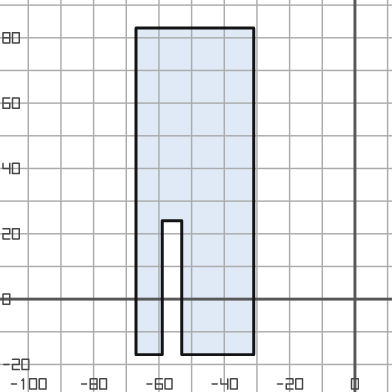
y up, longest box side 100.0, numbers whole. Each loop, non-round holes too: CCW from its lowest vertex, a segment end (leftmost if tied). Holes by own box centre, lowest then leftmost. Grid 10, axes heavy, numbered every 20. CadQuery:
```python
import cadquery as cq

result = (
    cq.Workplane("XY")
    .moveTo(-67.0, -17.0)
    .lineTo(-59.0, -17.0)
    .lineTo(-59.0, 24.0)
    .lineTo(-53.0, 24.0)
    .lineTo(-53.0, -17.0)
    .lineTo(-31.0, -17.0)
    .lineTo(-31.0, 83.0)
    .lineTo(-67.0, 83.0)
    .close()
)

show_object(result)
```